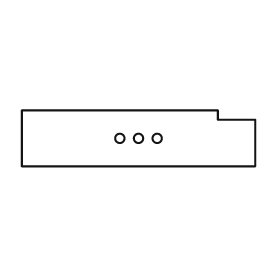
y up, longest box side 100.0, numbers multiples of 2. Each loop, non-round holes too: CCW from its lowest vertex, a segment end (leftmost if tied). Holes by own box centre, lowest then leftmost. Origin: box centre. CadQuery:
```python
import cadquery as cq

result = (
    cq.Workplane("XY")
    .moveTo(-50.0, -12.0)
    .lineTo(50.0, -12.0)
    .lineTo(50.0, 8.0)
    .lineTo(34.0, 8.0)
    .lineTo(34.0, 12.0)
    .lineTo(-50.0, 12.0)
    .close()
    .moveTo(-8.0, 0.0)
    .circle(2.0)
    .moveTo(0.0, 0.0)
    .circle(2.0)
    .moveTo(8.0, 0.0)
    .circle(2.0)
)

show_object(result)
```